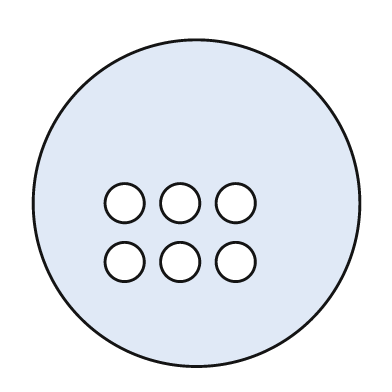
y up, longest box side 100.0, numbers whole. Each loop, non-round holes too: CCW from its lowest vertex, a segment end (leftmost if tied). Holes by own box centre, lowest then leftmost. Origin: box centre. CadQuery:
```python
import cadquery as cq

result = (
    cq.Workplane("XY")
    .moveTo(0.0, 0.0)
    .circle(50.0)
    .moveTo(-22.0, -18.0)
    .circle(6.0)
    .moveTo(-5.0, -18.0)
    .circle(6.0)
    .moveTo(12.0, -18.0)
    .circle(6.0)
    .moveTo(-22.0, 0.0)
    .circle(6.0)
    .moveTo(-5.0, 0.0)
    .circle(6.0)
    .moveTo(12.0, 0.0)
    .circle(6.0)
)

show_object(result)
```